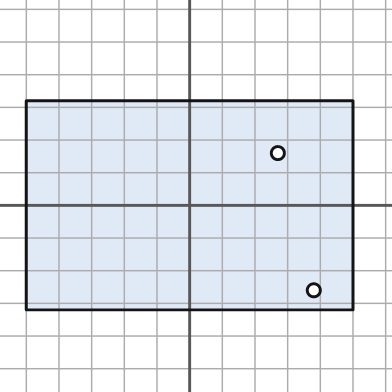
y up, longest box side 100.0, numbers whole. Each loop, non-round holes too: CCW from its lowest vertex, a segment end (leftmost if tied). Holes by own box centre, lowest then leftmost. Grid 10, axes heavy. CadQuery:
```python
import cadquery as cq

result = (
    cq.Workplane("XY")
    .moveTo(-50.0, -32.0)
    .lineTo(50.0, -32.0)
    .lineTo(50.0, 32.0)
    .lineTo(-50.0, 32.0)
    .close()
    .moveTo(38.0, -26.0)
    .circle(2.0)
    .moveTo(27.0, 16.0)
    .circle(2.0)
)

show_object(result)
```